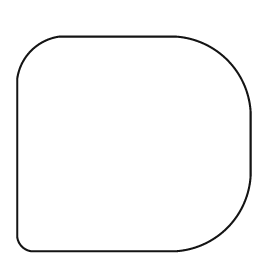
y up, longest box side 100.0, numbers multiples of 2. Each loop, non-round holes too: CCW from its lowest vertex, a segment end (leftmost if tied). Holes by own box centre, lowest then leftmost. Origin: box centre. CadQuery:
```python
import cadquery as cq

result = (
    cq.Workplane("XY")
    .moveTo(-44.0, -46.0)
    .lineTo(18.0, -46.0)
    .threePointArc((40.0, -36.0), (50.0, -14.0))
    .lineTo(50.0, 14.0)
    .threePointArc((40.0, 36.0), (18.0, 46.0))
    .lineTo(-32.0, 46.0)
    .threePointArc((-44.0, 40.0), (-50.0, 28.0))
    .lineTo(-50.0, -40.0)
    .threePointArc((-48.0, -44.0), (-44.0, -46.0))
    .close()
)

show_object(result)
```